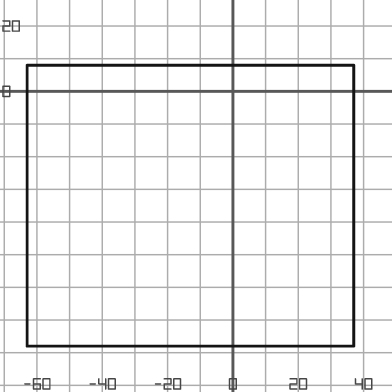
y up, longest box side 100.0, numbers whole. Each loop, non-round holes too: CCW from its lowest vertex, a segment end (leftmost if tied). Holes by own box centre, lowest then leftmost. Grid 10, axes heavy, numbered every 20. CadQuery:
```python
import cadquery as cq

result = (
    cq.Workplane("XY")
    .moveTo(-63.0, -78.0)
    .lineTo(37.0, -78.0)
    .lineTo(37.0, 8.0)
    .lineTo(-63.0, 8.0)
    .close()
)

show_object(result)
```